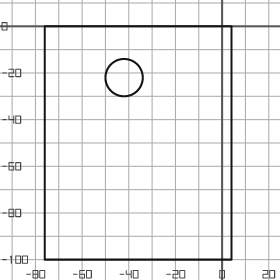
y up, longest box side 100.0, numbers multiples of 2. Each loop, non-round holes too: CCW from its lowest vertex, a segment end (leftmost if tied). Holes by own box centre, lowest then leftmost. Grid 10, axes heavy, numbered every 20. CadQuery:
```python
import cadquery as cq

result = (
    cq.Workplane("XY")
    .moveTo(-76.0, -100.0)
    .lineTo(4.0, -100.0)
    .lineTo(4.0, 0.0)
    .lineTo(-76.0, 0.0)
    .close()
    .moveTo(-42.0, -22.0)
    .circle(8.0)
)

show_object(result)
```